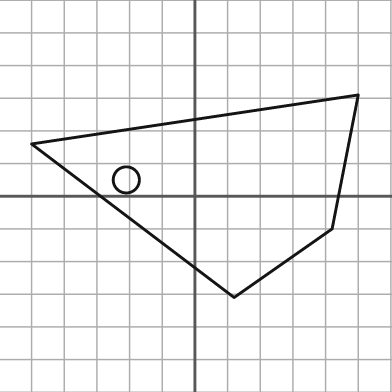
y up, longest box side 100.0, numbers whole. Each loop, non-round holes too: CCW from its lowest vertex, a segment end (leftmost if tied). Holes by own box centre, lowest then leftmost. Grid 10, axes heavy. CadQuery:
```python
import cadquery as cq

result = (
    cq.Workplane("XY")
    .moveTo(12.0, -31.0)
    .lineTo(42.0, -10.0)
    .lineTo(50.0, 31.0)
    .lineTo(-50.0, 16.0)
    .close()
    .moveTo(-21.0, 5.0)
    .circle(4.0)
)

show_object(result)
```